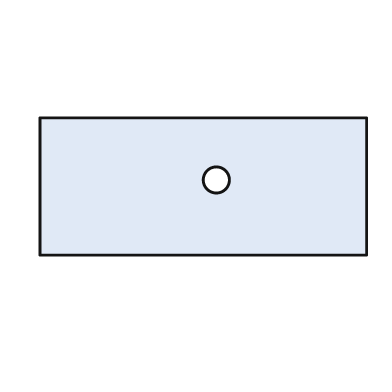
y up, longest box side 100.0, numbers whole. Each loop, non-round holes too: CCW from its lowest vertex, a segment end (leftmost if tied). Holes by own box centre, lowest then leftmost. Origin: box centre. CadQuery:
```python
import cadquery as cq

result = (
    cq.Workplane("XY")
    .moveTo(-50.0, -21.0)
    .lineTo(50.0, -21.0)
    .lineTo(50.0, 21.0)
    .lineTo(-50.0, 21.0)
    .close()
    .moveTo(4.0, 2.0)
    .circle(4.0)
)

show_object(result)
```